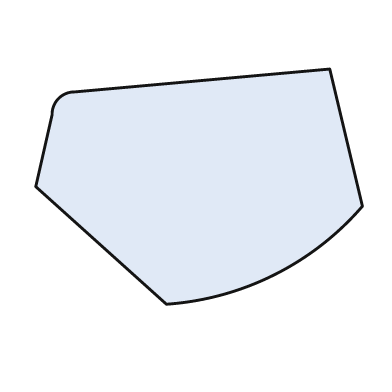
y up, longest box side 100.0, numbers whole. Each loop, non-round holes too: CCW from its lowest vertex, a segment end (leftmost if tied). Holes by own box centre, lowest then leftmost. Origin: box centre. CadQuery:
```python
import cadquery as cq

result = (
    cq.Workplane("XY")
    .moveTo(-10.0, -36.0)
    .threePointArc((23.0, -27.0), (50.0, -6.0))
    .lineTo(40.0, 36.0)
    .lineTo(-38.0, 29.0)
    .threePointArc((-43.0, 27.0), (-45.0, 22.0))
    .lineTo(-50.0, 0.0)
    .close()
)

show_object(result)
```